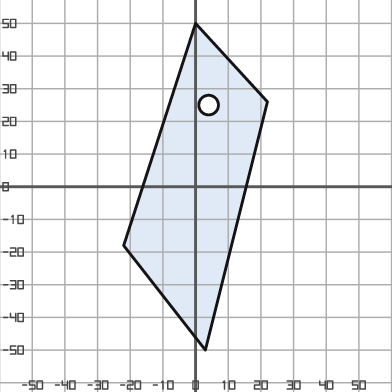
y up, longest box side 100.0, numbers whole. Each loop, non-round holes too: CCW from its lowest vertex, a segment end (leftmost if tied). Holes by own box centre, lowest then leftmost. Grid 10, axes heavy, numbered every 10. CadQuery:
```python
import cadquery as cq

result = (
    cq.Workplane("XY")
    .moveTo(3.0, -50.0)
    .lineTo(22.0, 26.0)
    .lineTo(0.0, 50.0)
    .lineTo(-22.0, -18.0)
    .close()
    .moveTo(4.0, 25.0)
    .circle(3.0)
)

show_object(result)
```